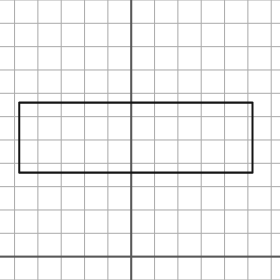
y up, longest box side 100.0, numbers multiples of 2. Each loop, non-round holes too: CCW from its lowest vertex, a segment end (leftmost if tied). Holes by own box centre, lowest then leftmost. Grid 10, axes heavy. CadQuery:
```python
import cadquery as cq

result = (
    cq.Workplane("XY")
    .moveTo(-48.0, 36.0)
    .lineTo(52.0, 36.0)
    .lineTo(52.0, 66.0)
    .lineTo(-48.0, 66.0)
    .close()
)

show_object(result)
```